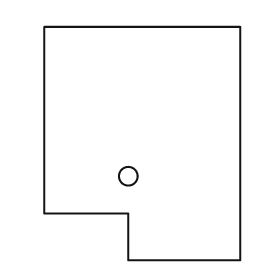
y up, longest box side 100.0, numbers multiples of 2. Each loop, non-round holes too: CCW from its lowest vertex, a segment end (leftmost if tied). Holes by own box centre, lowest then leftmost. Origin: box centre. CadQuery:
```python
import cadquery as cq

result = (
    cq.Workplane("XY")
    .moveTo(-6.0, -50.0)
    .lineTo(42.0, -50.0)
    .lineTo(42.0, 50.0)
    .lineTo(-42.0, 50.0)
    .lineTo(-42.0, -30.0)
    .lineTo(-6.0, -30.0)
    .close()
    .moveTo(-6.0, -14.0)
    .circle(4.0)
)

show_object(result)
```